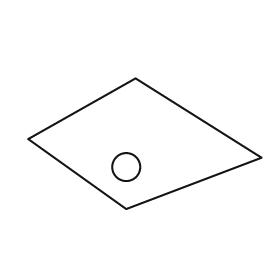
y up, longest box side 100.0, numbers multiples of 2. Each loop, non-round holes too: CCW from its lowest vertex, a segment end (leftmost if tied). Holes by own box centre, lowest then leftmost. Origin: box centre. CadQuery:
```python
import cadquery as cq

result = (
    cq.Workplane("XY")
    .moveTo(-8.0, -28.0)
    .lineTo(50.0, -6.0)
    .lineTo(-4.0, 28.0)
    .lineTo(-50.0, 2.0)
    .close()
    .moveTo(-8.0, -10.0)
    .circle(6.0)
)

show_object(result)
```